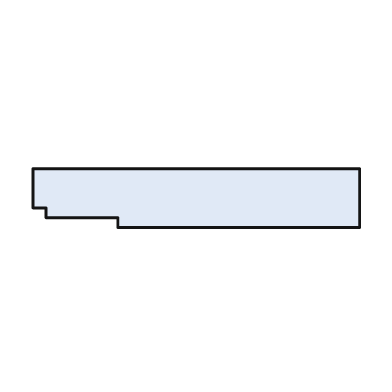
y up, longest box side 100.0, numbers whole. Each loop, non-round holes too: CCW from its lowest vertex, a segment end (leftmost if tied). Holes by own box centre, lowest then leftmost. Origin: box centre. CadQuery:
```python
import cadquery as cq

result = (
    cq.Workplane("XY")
    .moveTo(-24.0, -9.0)
    .lineTo(50.0, -9.0)
    .lineTo(50.0, 9.0)
    .lineTo(-50.0, 9.0)
    .lineTo(-50.0, -3.0)
    .lineTo(-46.0, -3.0)
    .lineTo(-46.0, -6.0)
    .lineTo(-24.0, -6.0)
    .close()
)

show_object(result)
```